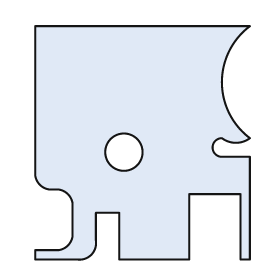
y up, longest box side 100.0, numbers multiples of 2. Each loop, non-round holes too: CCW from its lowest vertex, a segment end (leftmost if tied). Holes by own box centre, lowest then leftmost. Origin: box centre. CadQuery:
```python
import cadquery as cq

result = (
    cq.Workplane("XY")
    .moveTo(-46.0, -50.0)
    .lineTo(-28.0, -50.0)
    .threePointArc((-22.0, -48.0), (-20.0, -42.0))
    .lineTo(-20.0, -30.0)
    .lineTo(-10.0, -30.0)
    .lineTo(-10.0, -50.0)
    .lineTo(20.0, -50.0)
    .lineTo(20.0, -22.0)
    .lineTo(42.0, -22.0)
    .lineTo(42.0, -50.0)
    .lineTo(46.0, -50.0)
    .lineTo(46.0, -6.0)
    .lineTo(34.0, -6.0)
    .threePointArc((30.0, -2.0), (34.0, 2.0))
    .threePointArc((40.0, 0.0), (46.0, 2.0))
    .threePointArc((34.0, 26.0), (46.0, 50.0))
    .lineTo(-46.0, 50.0)
    .lineTo(-46.0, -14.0)
    .threePointArc((-44.0, -18.0), (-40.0, -20.0))
    .lineTo(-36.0, -20.0)
    .threePointArc((-32.0, -22.0), (-30.0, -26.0))
    .lineTo(-30.0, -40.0)
    .threePointArc((-32.0, -44.0), (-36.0, -46.0))
    .lineTo(-46.0, -46.0)
    .close()
    .moveTo(-8.0, -4.0)
    .circle(8.0)
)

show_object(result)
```